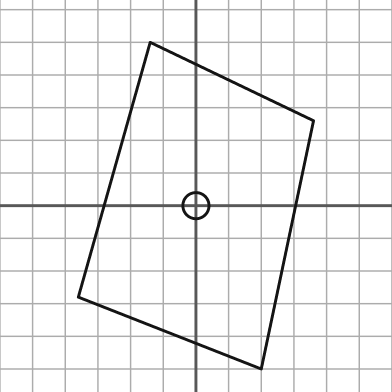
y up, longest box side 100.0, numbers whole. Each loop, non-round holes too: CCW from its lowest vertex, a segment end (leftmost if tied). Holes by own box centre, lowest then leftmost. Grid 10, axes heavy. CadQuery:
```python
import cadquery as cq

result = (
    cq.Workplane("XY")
    .moveTo(20.0, -50.0)
    .lineTo(36.0, 26.0)
    .lineTo(-14.0, 50.0)
    .lineTo(-36.0, -28.0)
    .close()
    .moveTo(0.0, 0.0)
    .circle(4.0)
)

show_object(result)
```